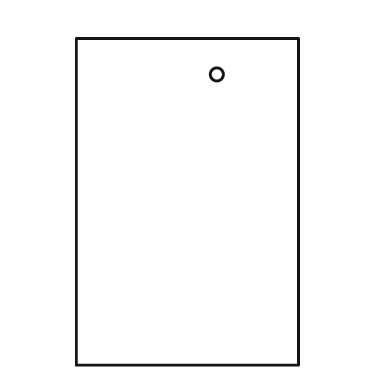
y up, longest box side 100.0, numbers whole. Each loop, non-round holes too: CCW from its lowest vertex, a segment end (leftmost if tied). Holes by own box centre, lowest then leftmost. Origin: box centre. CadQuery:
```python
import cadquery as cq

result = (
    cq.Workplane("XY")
    .moveTo(-34.0, -50.0)
    .lineTo(34.0, -50.0)
    .lineTo(34.0, 50.0)
    .lineTo(-34.0, 50.0)
    .close()
    .moveTo(9.0, 39.0)
    .circle(2.0)
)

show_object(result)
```